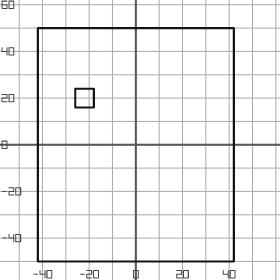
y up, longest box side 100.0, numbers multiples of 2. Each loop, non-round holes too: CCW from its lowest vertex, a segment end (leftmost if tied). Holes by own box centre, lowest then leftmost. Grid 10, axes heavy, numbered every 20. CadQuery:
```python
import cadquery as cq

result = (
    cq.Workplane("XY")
    .moveTo(-42.0, -50.0)
    .lineTo(42.0, -50.0)
    .lineTo(42.0, 50.0)
    .lineTo(-42.0, 50.0)
    .close()
    .moveTo(-26.0, 16.0)
    .lineTo(-18.0, 16.0)
    .lineTo(-18.0, 24.0)
    .lineTo(-26.0, 24.0)
    .close()
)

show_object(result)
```